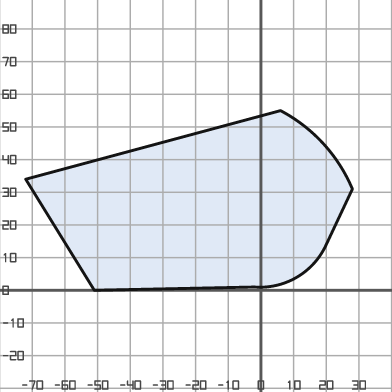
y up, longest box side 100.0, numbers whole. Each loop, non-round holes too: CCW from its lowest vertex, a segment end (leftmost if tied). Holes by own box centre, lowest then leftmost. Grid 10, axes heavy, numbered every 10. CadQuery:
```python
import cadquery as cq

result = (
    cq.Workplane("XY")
    .moveTo(-51.0, 0.0)
    .lineTo(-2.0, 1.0)
    .threePointArc((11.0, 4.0), (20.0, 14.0))
    .lineTo(28.0, 31.0)
    .threePointArc((19.0, 45.0), (6.0, 55.0))
    .lineTo(-72.0, 34.0)
    .close()
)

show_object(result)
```